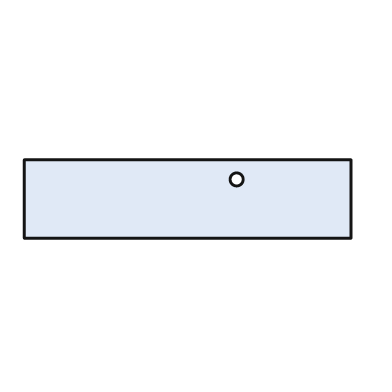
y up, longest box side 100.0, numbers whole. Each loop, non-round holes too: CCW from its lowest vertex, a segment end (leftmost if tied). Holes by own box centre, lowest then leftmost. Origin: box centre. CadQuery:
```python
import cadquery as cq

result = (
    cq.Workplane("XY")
    .moveTo(-50.0, -12.0)
    .lineTo(50.0, -12.0)
    .lineTo(50.0, 12.0)
    .lineTo(-50.0, 12.0)
    .close()
    .moveTo(15.0, 6.0)
    .circle(2.0)
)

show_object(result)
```